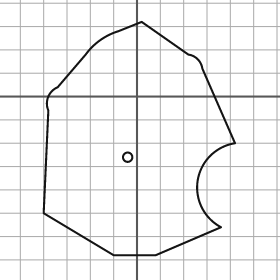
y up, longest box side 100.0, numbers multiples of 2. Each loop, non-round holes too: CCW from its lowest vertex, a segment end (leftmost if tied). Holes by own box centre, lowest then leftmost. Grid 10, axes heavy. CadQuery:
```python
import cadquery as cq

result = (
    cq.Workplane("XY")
    .moveTo(-10.0, -68.0)
    .lineTo(8.0, -68.0)
    .lineTo(36.0, -56.0)
    .threePointArc((26.0, -36.0), (42.0, -20.0))
    .lineTo(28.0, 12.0)
    .threePointArc((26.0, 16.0), (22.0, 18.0))
    .lineTo(2.0, 32.0)
    .lineTo(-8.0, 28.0)
    .threePointArc((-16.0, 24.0), (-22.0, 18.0))
    .lineTo(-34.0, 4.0)
    .threePointArc((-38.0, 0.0), (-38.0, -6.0))
    .lineTo(-40.0, -50.0)
    .close()
    .moveTo(-4.0, -26.0)
    .circle(2.0)
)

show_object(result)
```